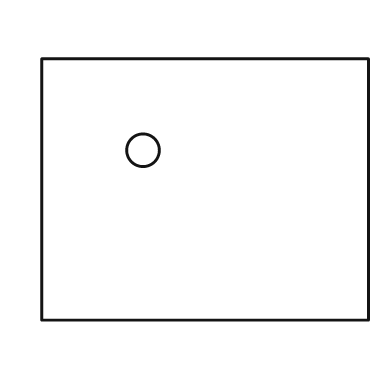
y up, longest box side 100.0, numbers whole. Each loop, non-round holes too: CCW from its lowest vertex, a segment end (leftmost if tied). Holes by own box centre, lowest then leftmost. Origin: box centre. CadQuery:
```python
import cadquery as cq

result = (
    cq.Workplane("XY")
    .moveTo(-50.0, -40.0)
    .lineTo(50.0, -40.0)
    .lineTo(50.0, 40.0)
    .lineTo(-50.0, 40.0)
    .close()
    .moveTo(-19.0, 12.0)
    .circle(5.0)
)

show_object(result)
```